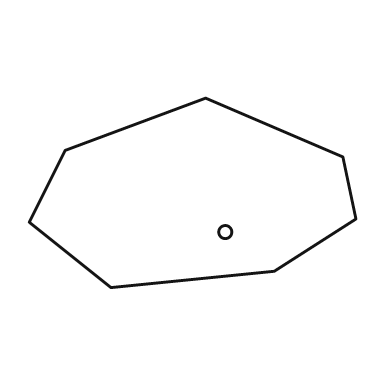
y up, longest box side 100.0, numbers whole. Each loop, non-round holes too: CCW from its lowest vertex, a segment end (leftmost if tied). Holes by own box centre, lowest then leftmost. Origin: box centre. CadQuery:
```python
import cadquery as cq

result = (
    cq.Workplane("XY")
    .moveTo(-25.0, -29.0)
    .lineTo(25.0, -24.0)
    .lineTo(50.0, -8.0)
    .lineTo(46.0, 11.0)
    .lineTo(4.0, 29.0)
    .lineTo(-39.0, 13.0)
    .lineTo(-50.0, -9.0)
    .close()
    .moveTo(10.0, -12.0)
    .circle(2.0)
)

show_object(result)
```